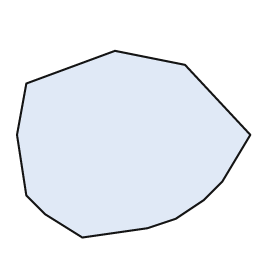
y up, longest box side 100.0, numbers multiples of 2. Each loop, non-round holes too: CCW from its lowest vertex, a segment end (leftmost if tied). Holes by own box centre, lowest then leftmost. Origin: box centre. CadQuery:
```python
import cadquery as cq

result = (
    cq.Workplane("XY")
    .moveTo(-22.0, -40.0)
    .lineTo(6.0, -36.0)
    .lineTo(18.0, -32.0)
    .lineTo(30.0, -24.0)
    .lineTo(38.0, -16.0)
    .lineTo(50.0, 4.0)
    .lineTo(22.0, 34.0)
    .lineTo(-8.0, 40.0)
    .lineTo(-46.0, 26.0)
    .lineTo(-50.0, 4.0)
    .lineTo(-46.0, -22.0)
    .lineTo(-38.0, -30.0)
    .close()
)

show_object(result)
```